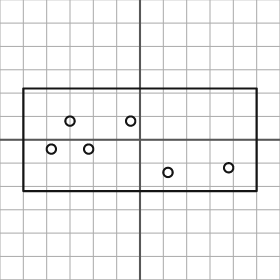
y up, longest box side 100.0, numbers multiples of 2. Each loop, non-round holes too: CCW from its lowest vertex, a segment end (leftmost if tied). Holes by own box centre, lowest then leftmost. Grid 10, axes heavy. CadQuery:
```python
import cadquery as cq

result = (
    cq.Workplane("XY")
    .moveTo(-50.0, -22.0)
    .lineTo(50.0, -22.0)
    .lineTo(50.0, 22.0)
    .lineTo(-50.0, 22.0)
    .close()
    .moveTo(12.0, -14.0)
    .circle(2.0)
    .moveTo(38.0, -12.0)
    .circle(2.0)
    .moveTo(-38.0, -4.0)
    .circle(2.0)
    .moveTo(-22.0, -4.0)
    .circle(2.0)
    .moveTo(-30.0, 8.0)
    .circle(2.0)
    .moveTo(-4.0, 8.0)
    .circle(2.0)
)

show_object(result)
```